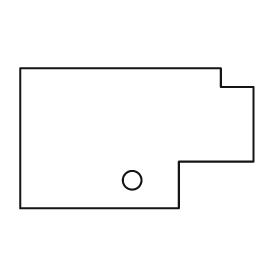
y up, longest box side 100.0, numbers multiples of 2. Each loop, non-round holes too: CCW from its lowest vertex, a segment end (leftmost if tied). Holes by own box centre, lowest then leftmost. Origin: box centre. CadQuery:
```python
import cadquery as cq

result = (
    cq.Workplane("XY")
    .moveTo(-50.0, -30.0)
    .lineTo(18.0, -30.0)
    .lineTo(18.0, -10.0)
    .lineTo(50.0, -10.0)
    .lineTo(50.0, 22.0)
    .lineTo(36.0, 22.0)
    .lineTo(36.0, 30.0)
    .lineTo(-50.0, 30.0)
    .close()
    .moveTo(-2.0, -18.0)
    .circle(4.0)
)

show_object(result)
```